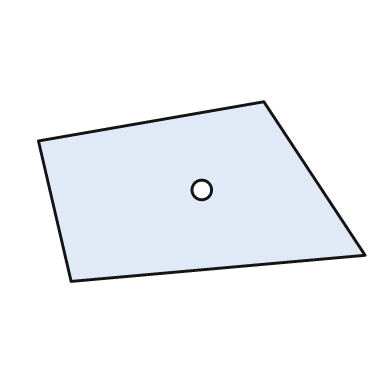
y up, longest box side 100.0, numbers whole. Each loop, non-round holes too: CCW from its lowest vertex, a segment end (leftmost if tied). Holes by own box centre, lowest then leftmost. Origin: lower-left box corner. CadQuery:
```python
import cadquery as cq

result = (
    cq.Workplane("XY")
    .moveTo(10.0, 0.0)
    .lineTo(100.0, 8.0)
    .lineTo(69.0, 55.0)
    .lineTo(0.0, 43.0)
    .close()
    .moveTo(50.0, 28.0)
    .circle(3.0)
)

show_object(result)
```